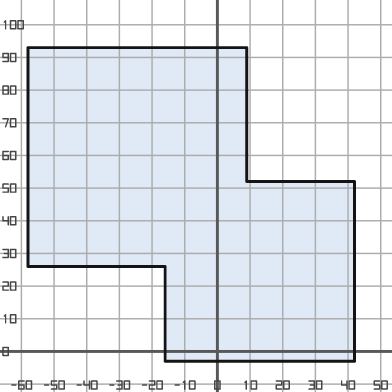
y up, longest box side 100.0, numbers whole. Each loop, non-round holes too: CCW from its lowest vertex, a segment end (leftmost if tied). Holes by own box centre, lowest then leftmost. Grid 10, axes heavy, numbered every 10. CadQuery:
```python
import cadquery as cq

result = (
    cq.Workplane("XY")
    .moveTo(-16.0, -3.0)
    .lineTo(42.0, -3.0)
    .lineTo(42.0, 52.0)
    .lineTo(9.0, 52.0)
    .lineTo(9.0, 93.0)
    .lineTo(-58.0, 93.0)
    .lineTo(-58.0, 26.0)
    .lineTo(-16.0, 26.0)
    .close()
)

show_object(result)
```